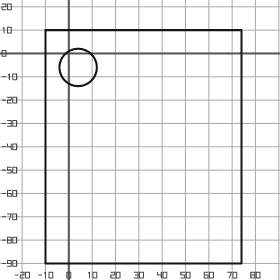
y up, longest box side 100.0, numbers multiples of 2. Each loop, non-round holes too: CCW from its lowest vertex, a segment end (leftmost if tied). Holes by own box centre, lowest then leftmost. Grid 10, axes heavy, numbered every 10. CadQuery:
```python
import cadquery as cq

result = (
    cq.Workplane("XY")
    .moveTo(-10.0, -90.0)
    .lineTo(74.0, -90.0)
    .lineTo(74.0, 10.0)
    .lineTo(-10.0, 10.0)
    .close()
    .moveTo(4.0, -6.0)
    .circle(8.0)
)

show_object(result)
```